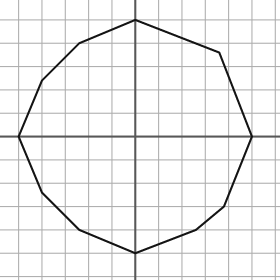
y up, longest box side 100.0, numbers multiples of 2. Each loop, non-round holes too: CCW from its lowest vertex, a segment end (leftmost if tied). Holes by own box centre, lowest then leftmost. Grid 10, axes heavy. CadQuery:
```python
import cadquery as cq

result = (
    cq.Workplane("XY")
    .moveTo(0.0, -50.0)
    .lineTo(26.0, -40.0)
    .lineTo(38.0, -30.0)
    .lineTo(50.0, 0.0)
    .lineTo(36.0, 36.0)
    .lineTo(0.0, 50.0)
    .lineTo(-24.0, 40.0)
    .lineTo(-40.0, 24.0)
    .lineTo(-50.0, 0.0)
    .lineTo(-40.0, -24.0)
    .lineTo(-24.0, -40.0)
    .close()
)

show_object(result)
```